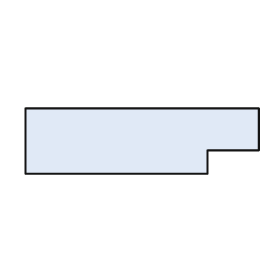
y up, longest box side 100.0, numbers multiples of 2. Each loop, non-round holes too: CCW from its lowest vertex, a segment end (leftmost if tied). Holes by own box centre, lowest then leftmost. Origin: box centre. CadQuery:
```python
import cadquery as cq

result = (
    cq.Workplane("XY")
    .moveTo(-50.0, -14.0)
    .lineTo(28.0, -14.0)
    .lineTo(28.0, -4.0)
    .lineTo(50.0, -4.0)
    .lineTo(50.0, 14.0)
    .lineTo(-50.0, 14.0)
    .close()
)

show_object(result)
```